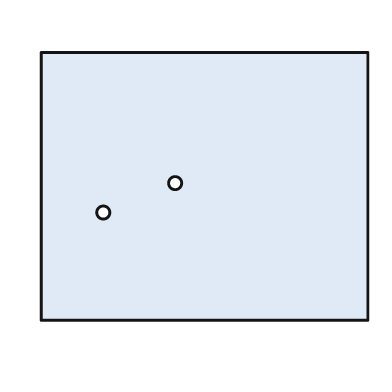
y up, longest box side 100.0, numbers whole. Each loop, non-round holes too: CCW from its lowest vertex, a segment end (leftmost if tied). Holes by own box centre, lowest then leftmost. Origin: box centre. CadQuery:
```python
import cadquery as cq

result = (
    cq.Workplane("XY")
    .moveTo(-50.0, -41.0)
    .lineTo(50.0, -41.0)
    .lineTo(50.0, 41.0)
    .lineTo(-50.0, 41.0)
    .close()
    .moveTo(-31.0, -8.0)
    .circle(2.0)
    .moveTo(-9.0, 1.0)
    .circle(2.0)
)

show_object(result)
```